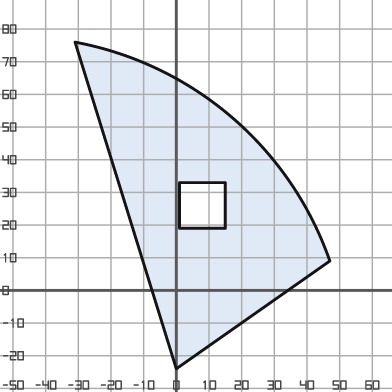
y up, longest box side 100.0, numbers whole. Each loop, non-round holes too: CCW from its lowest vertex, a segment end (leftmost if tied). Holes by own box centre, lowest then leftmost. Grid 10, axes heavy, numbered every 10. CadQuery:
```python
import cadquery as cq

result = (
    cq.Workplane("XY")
    .moveTo(0.0, -24.0)
    .lineTo(47.0, 9.0)
    .threePointArc((17.0, 53.0), (-31.0, 76.0))
    .close()
    .moveTo(1.0, 19.0)
    .lineTo(15.0, 19.0)
    .lineTo(15.0, 33.0)
    .lineTo(1.0, 33.0)
    .close()
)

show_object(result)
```